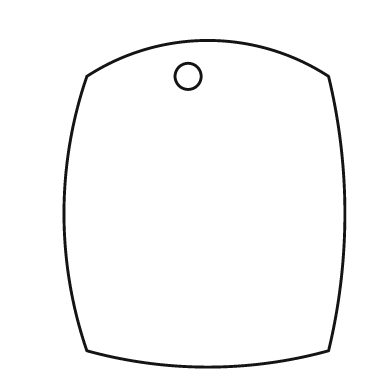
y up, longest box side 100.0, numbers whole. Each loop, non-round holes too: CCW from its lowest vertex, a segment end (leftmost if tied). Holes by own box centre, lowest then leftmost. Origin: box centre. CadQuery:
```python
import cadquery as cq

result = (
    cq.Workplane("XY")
    .moveTo(-36.0, -45.0)
    .threePointArc((1.0, -50.0), (38.0, -45.0))
    .threePointArc((43.0, -3.0), (38.0, 39.0))
    .threePointArc((1.0, 50.0), (-36.0, 39.0))
    .threePointArc((-43.0, -3.0), (-36.0, -45.0))
    .close()
    .moveTo(-5.0, 39.0)
    .circle(4.0)
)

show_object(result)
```